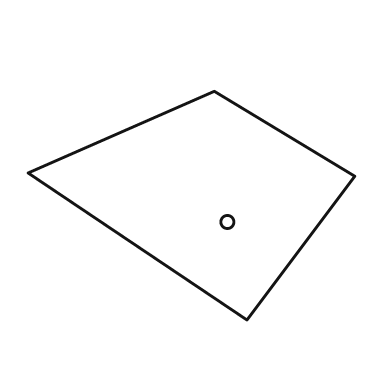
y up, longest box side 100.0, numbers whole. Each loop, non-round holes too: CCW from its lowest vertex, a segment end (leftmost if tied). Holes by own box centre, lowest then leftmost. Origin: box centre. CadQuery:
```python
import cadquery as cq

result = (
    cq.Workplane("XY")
    .moveTo(17.0, -35.0)
    .lineTo(50.0, 9.0)
    .lineTo(7.0, 35.0)
    .lineTo(-50.0, 10.0)
    .close()
    .moveTo(11.0, -5.0)
    .circle(2.0)
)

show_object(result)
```